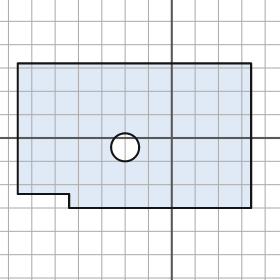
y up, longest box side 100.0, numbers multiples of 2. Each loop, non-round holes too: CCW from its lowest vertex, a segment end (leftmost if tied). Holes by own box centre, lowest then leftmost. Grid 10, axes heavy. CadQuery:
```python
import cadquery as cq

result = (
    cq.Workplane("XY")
    .moveTo(-44.0, -30.0)
    .lineTo(34.0, -30.0)
    .lineTo(34.0, 32.0)
    .lineTo(-66.0, 32.0)
    .lineTo(-66.0, -24.0)
    .lineTo(-44.0, -24.0)
    .close()
    .moveTo(-20.0, -4.0)
    .circle(6.0)
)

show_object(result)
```